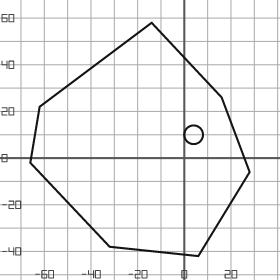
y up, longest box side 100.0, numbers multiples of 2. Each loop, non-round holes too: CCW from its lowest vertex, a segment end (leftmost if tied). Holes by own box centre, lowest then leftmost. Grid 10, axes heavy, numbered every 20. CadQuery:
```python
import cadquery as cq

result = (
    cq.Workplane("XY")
    .moveTo(6.0, -42.0)
    .lineTo(28.0, -6.0)
    .lineTo(16.0, 26.0)
    .lineTo(-14.0, 58.0)
    .lineTo(-62.0, 22.0)
    .lineTo(-66.0, -2.0)
    .lineTo(-32.0, -38.0)
    .close()
    .moveTo(4.0, 10.0)
    .circle(4.0)
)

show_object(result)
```